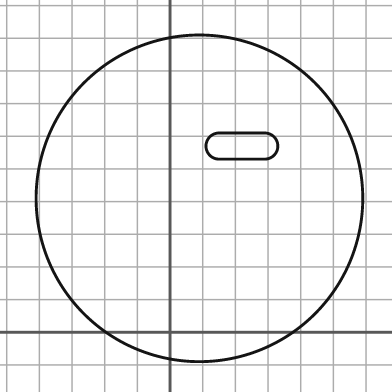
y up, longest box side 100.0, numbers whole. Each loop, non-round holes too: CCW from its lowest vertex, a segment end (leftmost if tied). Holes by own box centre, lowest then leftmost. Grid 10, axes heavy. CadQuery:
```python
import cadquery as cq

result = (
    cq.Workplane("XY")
    .moveTo(9.0, 41.0)
    .circle(50.0)
    .moveTo(15.0, 53.0)
    .lineTo(29.0, 53.0)
    .threePointArc((33.0, 57.0), (29.0, 61.0))
    .lineTo(15.0, 61.0)
    .threePointArc((11.0, 57.0), (15.0, 53.0))
    .close()
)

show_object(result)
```